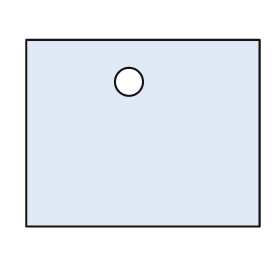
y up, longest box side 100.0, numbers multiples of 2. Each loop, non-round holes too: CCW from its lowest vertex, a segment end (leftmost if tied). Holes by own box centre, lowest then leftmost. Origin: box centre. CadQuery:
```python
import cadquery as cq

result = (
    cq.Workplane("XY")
    .moveTo(-50.0, -40.0)
    .lineTo(50.0, -40.0)
    .lineTo(50.0, 40.0)
    .lineTo(-50.0, 40.0)
    .close()
    .moveTo(-6.0, 22.0)
    .circle(6.0)
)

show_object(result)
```